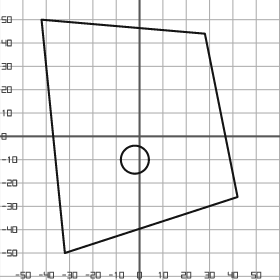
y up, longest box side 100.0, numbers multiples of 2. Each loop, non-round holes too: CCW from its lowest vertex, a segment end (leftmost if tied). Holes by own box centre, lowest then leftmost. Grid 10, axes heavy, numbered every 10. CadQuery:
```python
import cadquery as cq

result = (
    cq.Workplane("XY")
    .moveTo(-32.0, -50.0)
    .lineTo(42.0, -26.0)
    .lineTo(28.0, 44.0)
    .lineTo(-42.0, 50.0)
    .close()
    .moveTo(-2.0, -10.0)
    .circle(6.0)
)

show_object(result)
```